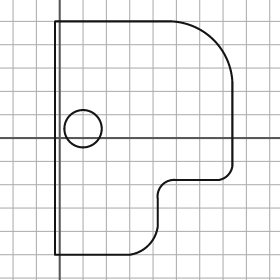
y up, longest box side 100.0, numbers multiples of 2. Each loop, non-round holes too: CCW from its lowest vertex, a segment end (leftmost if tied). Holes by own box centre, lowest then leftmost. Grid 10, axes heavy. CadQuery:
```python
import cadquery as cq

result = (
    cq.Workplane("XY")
    .moveTo(-2.0, -50.0)
    .lineTo(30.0, -50.0)
    .threePointArc((38.0, -46.0), (42.0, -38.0))
    .lineTo(42.0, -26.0)
    .threePointArc((44.0, -20.0), (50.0, -18.0))
    .lineTo(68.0, -18.0)
    .threePointArc((72.0, -16.0), (74.0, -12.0))
    .lineTo(74.0, 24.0)
    .threePointArc((66.0, 42.0), (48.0, 50.0))
    .lineTo(-2.0, 50.0)
    .close()
    .moveTo(10.0, 4.0)
    .circle(8.0)
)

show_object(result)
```